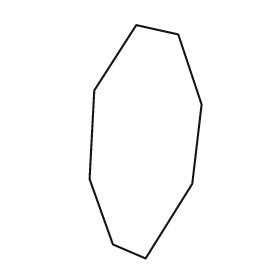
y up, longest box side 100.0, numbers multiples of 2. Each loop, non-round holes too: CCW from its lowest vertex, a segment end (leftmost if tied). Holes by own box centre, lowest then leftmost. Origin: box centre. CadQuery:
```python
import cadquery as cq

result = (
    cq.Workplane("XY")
    .moveTo(0.0, -50.0)
    .lineTo(20.0, -18.0)
    .lineTo(24.0, 16.0)
    .lineTo(14.0, 46.0)
    .lineTo(-4.0, 50.0)
    .lineTo(-22.0, 22.0)
    .lineTo(-24.0, -16.0)
    .lineTo(-14.0, -44.0)
    .close()
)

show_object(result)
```